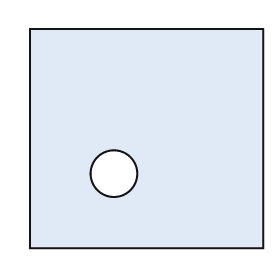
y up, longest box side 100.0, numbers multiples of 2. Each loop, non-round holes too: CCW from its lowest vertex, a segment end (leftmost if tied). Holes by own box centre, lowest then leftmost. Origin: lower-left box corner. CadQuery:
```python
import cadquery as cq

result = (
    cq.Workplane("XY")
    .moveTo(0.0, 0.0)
    .lineTo(100.0, 0.0)
    .lineTo(100.0, 94.0)
    .lineTo(0.0, 94.0)
    .close()
    .moveTo(36.0, 32.0)
    .circle(10.0)
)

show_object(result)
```